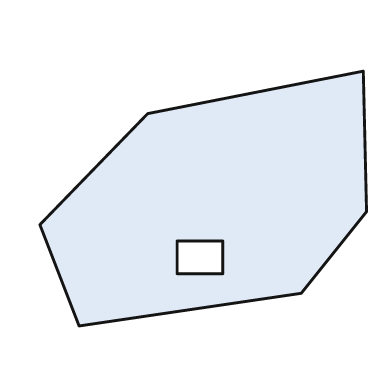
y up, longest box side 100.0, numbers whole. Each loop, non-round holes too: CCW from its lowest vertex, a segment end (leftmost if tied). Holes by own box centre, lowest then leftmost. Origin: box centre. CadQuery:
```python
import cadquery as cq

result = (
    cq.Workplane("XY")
    .moveTo(-38.0, -39.0)
    .lineTo(30.0, -29.0)
    .lineTo(50.0, -4.0)
    .lineTo(49.0, 39.0)
    .lineTo(-17.0, 26.0)
    .lineTo(-50.0, -8.0)
    .close()
    .moveTo(-8.0, -23.0)
    .lineTo(6.0, -23.0)
    .lineTo(6.0, -13.0)
    .lineTo(-8.0, -13.0)
    .close()
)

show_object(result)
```